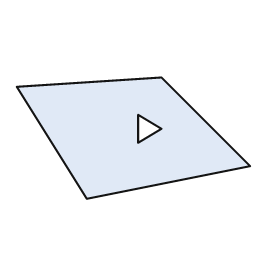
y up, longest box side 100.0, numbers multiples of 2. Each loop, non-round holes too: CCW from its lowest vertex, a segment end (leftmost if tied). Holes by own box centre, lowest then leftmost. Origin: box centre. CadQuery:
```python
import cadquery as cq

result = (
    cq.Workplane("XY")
    .moveTo(-20.0, -26.0)
    .lineTo(50.0, -12.0)
    .lineTo(12.0, 26.0)
    .lineTo(-50.0, 22.0)
    .close()
    .moveTo(2.0, -2.0)
    .lineTo(12.0, 4.0)
    .lineTo(2.0, 10.0)
    .close()
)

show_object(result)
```